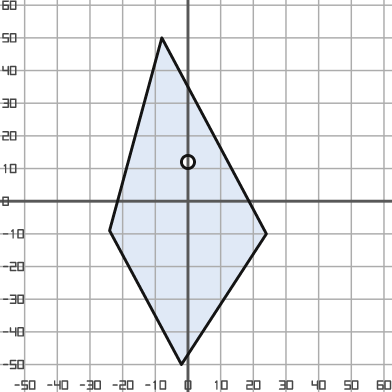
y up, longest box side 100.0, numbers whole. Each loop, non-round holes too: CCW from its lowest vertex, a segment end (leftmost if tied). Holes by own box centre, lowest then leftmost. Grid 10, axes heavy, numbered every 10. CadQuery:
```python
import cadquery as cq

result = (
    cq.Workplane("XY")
    .moveTo(-2.0, -50.0)
    .lineTo(24.0, -10.0)
    .lineTo(-8.0, 50.0)
    .lineTo(-24.0, -9.0)
    .close()
    .moveTo(0.0, 12.0)
    .circle(2.0)
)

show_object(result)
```